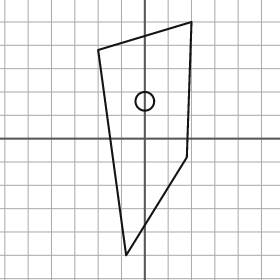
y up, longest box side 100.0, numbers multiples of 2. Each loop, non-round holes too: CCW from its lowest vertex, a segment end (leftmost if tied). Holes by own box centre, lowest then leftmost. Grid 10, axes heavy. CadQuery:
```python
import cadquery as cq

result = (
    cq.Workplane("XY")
    .moveTo(-8.0, -50.0)
    .lineTo(18.0, -8.0)
    .lineTo(20.0, 50.0)
    .lineTo(-20.0, 38.0)
    .close()
    .moveTo(0.0, 16.0)
    .circle(4.0)
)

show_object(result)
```